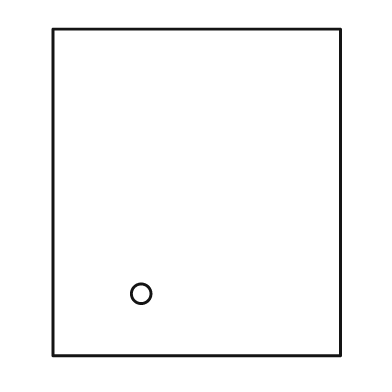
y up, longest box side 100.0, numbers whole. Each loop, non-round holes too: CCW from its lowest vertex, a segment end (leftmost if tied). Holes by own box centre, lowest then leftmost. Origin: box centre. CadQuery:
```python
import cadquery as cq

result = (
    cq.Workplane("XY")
    .moveTo(-44.0, -50.0)
    .lineTo(44.0, -50.0)
    .lineTo(44.0, 50.0)
    .lineTo(-44.0, 50.0)
    .close()
    .moveTo(-17.0, -31.0)
    .circle(3.0)
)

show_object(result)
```